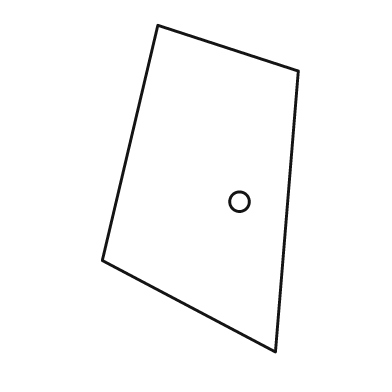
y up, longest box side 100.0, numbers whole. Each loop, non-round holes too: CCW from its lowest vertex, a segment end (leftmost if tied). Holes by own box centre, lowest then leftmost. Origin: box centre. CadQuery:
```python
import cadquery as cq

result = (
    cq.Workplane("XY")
    .moveTo(23.0, -50.0)
    .lineTo(30.0, 36.0)
    .lineTo(-13.0, 50.0)
    .lineTo(-30.0, -22.0)
    .close()
    .moveTo(12.0, -4.0)
    .circle(3.0)
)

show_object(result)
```